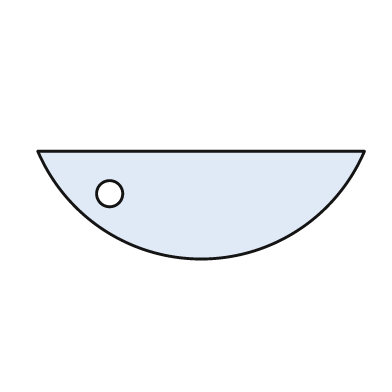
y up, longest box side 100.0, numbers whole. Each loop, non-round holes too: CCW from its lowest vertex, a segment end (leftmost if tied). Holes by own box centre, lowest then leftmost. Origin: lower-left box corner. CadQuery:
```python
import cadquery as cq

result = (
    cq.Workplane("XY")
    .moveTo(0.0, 33.0)
    .threePointArc((50.0, 0.0), (100.0, 33.0))
    .close()
    .moveTo(22.0, 20.0)
    .circle(4.0)
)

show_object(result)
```